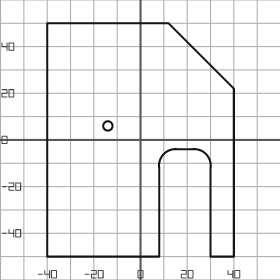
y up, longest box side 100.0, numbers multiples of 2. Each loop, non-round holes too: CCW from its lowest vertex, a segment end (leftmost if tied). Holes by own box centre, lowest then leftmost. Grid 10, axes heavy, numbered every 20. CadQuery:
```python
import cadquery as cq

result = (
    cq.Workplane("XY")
    .moveTo(-40.0, -50.0)
    .lineTo(8.0, -50.0)
    .lineTo(8.0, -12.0)
    .threePointArc((10.0, -6.0), (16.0, -4.0))
    .lineTo(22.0, -4.0)
    .threePointArc((28.0, -6.0), (30.0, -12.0))
    .lineTo(30.0, -50.0)
    .lineTo(40.0, -50.0)
    .lineTo(40.0, 22.0)
    .lineTo(12.0, 50.0)
    .lineTo(-40.0, 50.0)
    .close()
    .moveTo(-14.0, 6.0)
    .circle(2.0)
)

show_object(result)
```